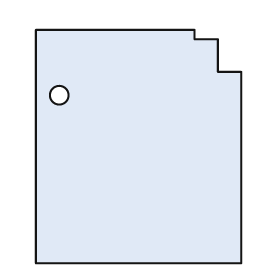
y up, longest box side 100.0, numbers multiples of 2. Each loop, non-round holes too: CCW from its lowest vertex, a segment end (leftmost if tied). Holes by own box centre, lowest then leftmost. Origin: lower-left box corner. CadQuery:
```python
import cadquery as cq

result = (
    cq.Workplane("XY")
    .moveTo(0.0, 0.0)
    .lineTo(88.0, 0.0)
    .lineTo(88.0, 82.0)
    .lineTo(78.0, 82.0)
    .lineTo(78.0, 96.0)
    .lineTo(68.0, 96.0)
    .lineTo(68.0, 100.0)
    .lineTo(0.0, 100.0)
    .close()
    .moveTo(10.0, 72.0)
    .circle(4.0)
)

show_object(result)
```